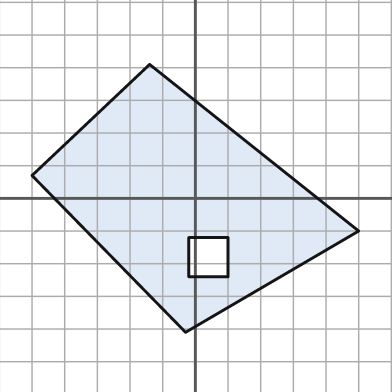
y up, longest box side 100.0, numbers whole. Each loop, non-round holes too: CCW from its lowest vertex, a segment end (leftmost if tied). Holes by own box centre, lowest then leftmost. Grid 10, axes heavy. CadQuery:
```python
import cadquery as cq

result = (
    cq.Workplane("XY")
    .moveTo(-3.0, -41.0)
    .lineTo(50.0, -10.0)
    .lineTo(-14.0, 41.0)
    .lineTo(-50.0, 7.0)
    .close()
    .moveTo(-2.0, -24.0)
    .lineTo(10.0, -24.0)
    .lineTo(10.0, -12.0)
    .lineTo(-2.0, -12.0)
    .close()
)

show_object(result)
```